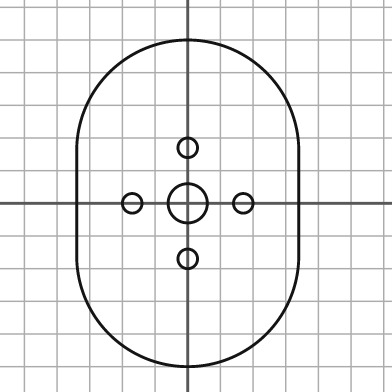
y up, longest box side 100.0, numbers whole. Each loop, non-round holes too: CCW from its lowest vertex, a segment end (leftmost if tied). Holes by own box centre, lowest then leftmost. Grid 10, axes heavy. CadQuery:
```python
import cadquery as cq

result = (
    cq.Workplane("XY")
    .moveTo(-34.0, -16.0)
    .threePointArc((0.0, -50.0), (34.0, -16.0))
    .lineTo(34.0, 16.0)
    .threePointArc((0.0, 50.0), (-34.0, 16.0))
    .close()
    .moveTo(0.0, -17.0)
    .circle(3.0)
    .moveTo(-17.0, 0.0)
    .circle(3.0)
    .moveTo(0.0, 0.0)
    .circle(6.0)
    .moveTo(17.0, 0.0)
    .circle(3.0)
    .moveTo(0.0, 17.0)
    .circle(3.0)
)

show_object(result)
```